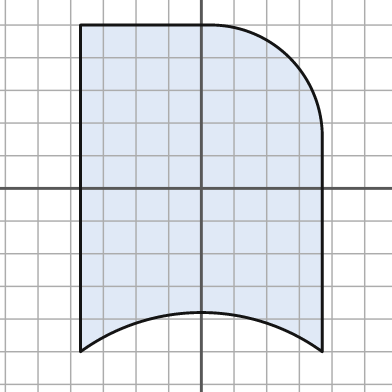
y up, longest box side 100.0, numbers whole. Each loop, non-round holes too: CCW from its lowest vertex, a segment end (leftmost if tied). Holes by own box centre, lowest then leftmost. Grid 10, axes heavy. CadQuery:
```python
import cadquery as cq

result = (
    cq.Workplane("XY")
    .moveTo(-37.0, -50.0)
    .threePointArc((0.0, -38.0), (37.0, -50.0))
    .lineTo(37.0, 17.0)
    .threePointArc((27.0, 40.0), (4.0, 50.0))
    .lineTo(-37.0, 50.0)
    .close()
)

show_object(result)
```